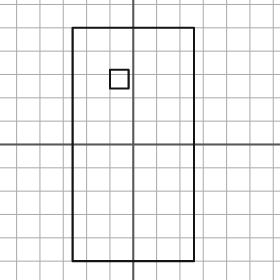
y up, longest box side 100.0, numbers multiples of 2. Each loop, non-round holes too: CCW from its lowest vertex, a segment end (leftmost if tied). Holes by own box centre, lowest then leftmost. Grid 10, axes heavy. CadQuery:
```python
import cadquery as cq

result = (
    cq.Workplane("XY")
    .moveTo(-26.0, -50.0)
    .lineTo(26.0, -50.0)
    .lineTo(26.0, 50.0)
    .lineTo(-26.0, 50.0)
    .close()
    .moveTo(-10.0, 24.0)
    .lineTo(-2.0, 24.0)
    .lineTo(-2.0, 32.0)
    .lineTo(-10.0, 32.0)
    .close()
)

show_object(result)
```